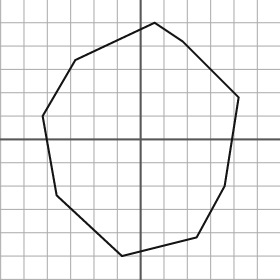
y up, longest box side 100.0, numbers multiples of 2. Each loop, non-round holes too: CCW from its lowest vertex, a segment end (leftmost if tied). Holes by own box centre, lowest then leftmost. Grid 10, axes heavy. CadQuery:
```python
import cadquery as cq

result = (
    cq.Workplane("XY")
    .moveTo(-8.0, -50.0)
    .lineTo(24.0, -42.0)
    .lineTo(36.0, -20.0)
    .lineTo(42.0, 18.0)
    .lineTo(18.0, 42.0)
    .lineTo(6.0, 50.0)
    .lineTo(-28.0, 34.0)
    .lineTo(-42.0, 10.0)
    .lineTo(-36.0, -24.0)
    .close()
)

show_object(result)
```